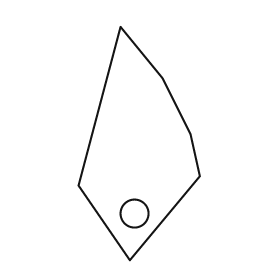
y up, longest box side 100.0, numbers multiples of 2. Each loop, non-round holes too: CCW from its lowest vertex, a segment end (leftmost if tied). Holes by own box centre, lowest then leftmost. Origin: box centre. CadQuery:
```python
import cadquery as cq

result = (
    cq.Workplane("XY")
    .moveTo(-4.0, -50.0)
    .lineTo(26.0, -14.0)
    .lineTo(22.0, 4.0)
    .lineTo(10.0, 28.0)
    .lineTo(-8.0, 50.0)
    .lineTo(-26.0, -18.0)
    .close()
    .moveTo(-2.0, -30.0)
    .circle(6.0)
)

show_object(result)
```